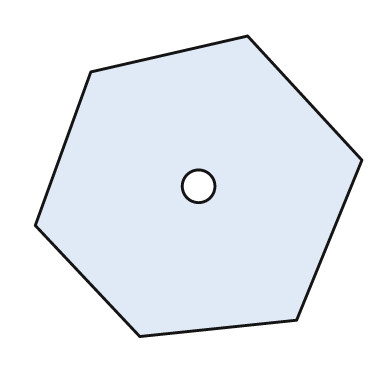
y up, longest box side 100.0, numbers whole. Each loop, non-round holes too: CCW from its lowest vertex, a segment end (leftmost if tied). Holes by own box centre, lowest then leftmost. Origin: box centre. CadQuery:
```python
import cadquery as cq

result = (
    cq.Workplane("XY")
    .moveTo(-18.0, -46.0)
    .lineTo(30.0, -41.0)
    .lineTo(50.0, 8.0)
    .lineTo(15.0, 46.0)
    .lineTo(-33.0, 35.0)
    .lineTo(-50.0, -12.0)
    .close()
    .moveTo(0.0, 0.0)
    .circle(5.0)
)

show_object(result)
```